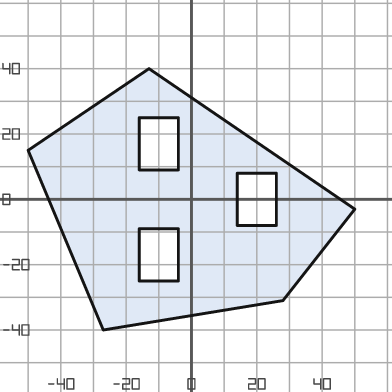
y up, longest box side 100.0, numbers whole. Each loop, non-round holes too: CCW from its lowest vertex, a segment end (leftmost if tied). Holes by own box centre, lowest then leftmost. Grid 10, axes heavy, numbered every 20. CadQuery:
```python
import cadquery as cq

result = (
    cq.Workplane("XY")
    .moveTo(-27.0, -40.0)
    .lineTo(28.0, -31.0)
    .lineTo(50.0, -3.0)
    .lineTo(-13.0, 40.0)
    .lineTo(-50.0, 15.0)
    .close()
    .moveTo(-16.0, -25.0)
    .lineTo(-4.0, -25.0)
    .lineTo(-4.0, -9.0)
    .lineTo(-16.0, -9.0)
    .close()
    .moveTo(14.0, -8.0)
    .lineTo(26.0, -8.0)
    .lineTo(26.0, 8.0)
    .lineTo(14.0, 8.0)
    .close()
    .moveTo(-16.0, 9.0)
    .lineTo(-4.0, 9.0)
    .lineTo(-4.0, 25.0)
    .lineTo(-16.0, 25.0)
    .close()
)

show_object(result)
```